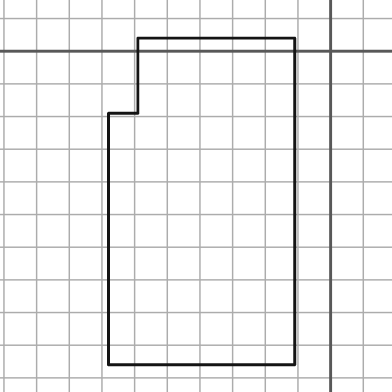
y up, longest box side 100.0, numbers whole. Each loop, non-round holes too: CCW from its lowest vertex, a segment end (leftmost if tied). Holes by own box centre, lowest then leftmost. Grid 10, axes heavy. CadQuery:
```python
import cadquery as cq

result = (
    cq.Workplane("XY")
    .moveTo(-68.0, -96.0)
    .lineTo(-11.0, -96.0)
    .lineTo(-11.0, 4.0)
    .lineTo(-59.0, 4.0)
    .lineTo(-59.0, -19.0)
    .lineTo(-68.0, -19.0)
    .close()
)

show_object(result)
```